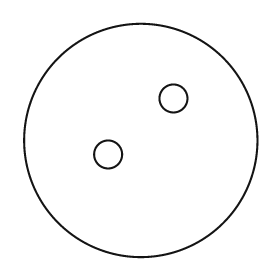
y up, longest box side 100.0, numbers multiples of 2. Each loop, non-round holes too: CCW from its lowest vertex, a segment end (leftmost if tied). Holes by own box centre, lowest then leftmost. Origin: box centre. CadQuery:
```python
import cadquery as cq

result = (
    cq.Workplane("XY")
    .moveTo(0.0, 0.0)
    .circle(50.0)
    .moveTo(-14.0, -6.0)
    .circle(6.0)
    .moveTo(14.0, 18.0)
    .circle(6.0)
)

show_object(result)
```